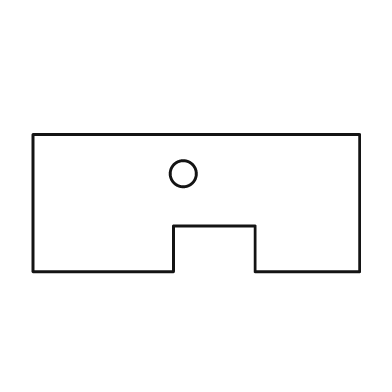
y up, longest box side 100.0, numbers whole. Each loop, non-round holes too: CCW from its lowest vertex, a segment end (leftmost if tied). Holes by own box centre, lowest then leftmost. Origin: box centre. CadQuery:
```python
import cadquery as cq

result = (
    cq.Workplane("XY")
    .moveTo(-50.0, -21.0)
    .lineTo(-7.0, -21.0)
    .lineTo(-7.0, -7.0)
    .lineTo(18.0, -7.0)
    .lineTo(18.0, -21.0)
    .lineTo(50.0, -21.0)
    .lineTo(50.0, 21.0)
    .lineTo(-50.0, 21.0)
    .close()
    .moveTo(-4.0, 9.0)
    .circle(4.0)
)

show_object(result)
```